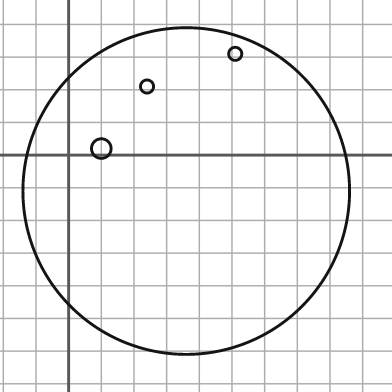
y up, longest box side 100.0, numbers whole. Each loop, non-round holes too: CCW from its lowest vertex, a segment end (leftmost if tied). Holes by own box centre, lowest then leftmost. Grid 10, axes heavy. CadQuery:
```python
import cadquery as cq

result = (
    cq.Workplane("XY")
    .moveTo(36.0, -11.0)
    .circle(50.0)
    .moveTo(10.0, 2.0)
    .circle(3.0)
    .moveTo(24.0, 21.0)
    .circle(2.0)
    .moveTo(51.0, 31.0)
    .circle(2.0)
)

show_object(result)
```